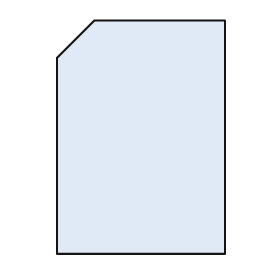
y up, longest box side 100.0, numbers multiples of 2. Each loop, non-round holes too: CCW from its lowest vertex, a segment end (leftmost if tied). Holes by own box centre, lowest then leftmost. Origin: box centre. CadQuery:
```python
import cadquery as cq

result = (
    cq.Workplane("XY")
    .moveTo(-36.0, -50.0)
    .lineTo(36.0, -50.0)
    .lineTo(36.0, 50.0)
    .lineTo(-20.0, 50.0)
    .lineTo(-36.0, 34.0)
    .close()
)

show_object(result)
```